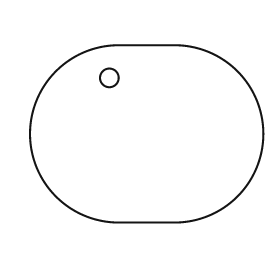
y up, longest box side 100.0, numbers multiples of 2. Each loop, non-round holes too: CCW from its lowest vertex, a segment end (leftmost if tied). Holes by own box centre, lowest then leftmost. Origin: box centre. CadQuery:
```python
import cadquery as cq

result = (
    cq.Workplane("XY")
    .moveTo(-12.0, -38.0)
    .lineTo(12.0, -38.0)
    .threePointArc((50.0, 0.0), (12.0, 38.0))
    .lineTo(-12.0, 38.0)
    .threePointArc((-50.0, 0.0), (-12.0, -38.0))
    .close()
    .moveTo(-16.0, 24.0)
    .circle(4.0)
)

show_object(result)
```